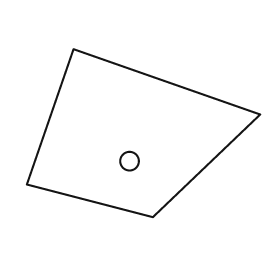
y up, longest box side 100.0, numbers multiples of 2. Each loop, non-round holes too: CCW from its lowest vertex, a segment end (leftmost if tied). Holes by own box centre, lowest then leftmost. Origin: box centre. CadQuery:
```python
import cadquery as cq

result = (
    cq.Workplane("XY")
    .moveTo(4.0, -36.0)
    .lineTo(50.0, 8.0)
    .lineTo(-30.0, 36.0)
    .lineTo(-50.0, -22.0)
    .close()
    .moveTo(-6.0, -12.0)
    .circle(4.0)
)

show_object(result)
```